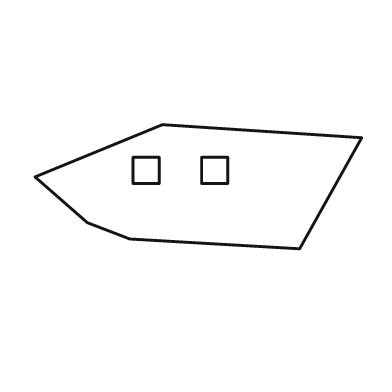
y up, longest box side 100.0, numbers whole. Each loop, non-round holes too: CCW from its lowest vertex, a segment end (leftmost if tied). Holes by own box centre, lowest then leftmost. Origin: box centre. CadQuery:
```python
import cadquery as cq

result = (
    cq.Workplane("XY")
    .moveTo(31.0, -19.0)
    .lineTo(50.0, 15.0)
    .lineTo(-11.0, 19.0)
    .lineTo(-50.0, 3.0)
    .lineTo(-34.0, -11.0)
    .lineTo(-21.0, -16.0)
    .close()
    .moveTo(-20.0, 1.0)
    .lineTo(-12.0, 1.0)
    .lineTo(-12.0, 9.0)
    .lineTo(-20.0, 9.0)
    .close()
    .moveTo(1.0, 1.0)
    .lineTo(9.0, 1.0)
    .lineTo(9.0, 9.0)
    .lineTo(1.0, 9.0)
    .close()
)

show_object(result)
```